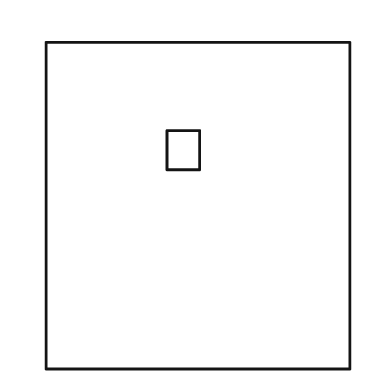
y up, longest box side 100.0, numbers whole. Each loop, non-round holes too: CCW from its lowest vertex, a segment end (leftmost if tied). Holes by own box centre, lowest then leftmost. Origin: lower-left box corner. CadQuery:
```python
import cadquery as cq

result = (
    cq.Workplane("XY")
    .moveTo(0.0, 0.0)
    .lineTo(93.0, 0.0)
    .lineTo(93.0, 100.0)
    .lineTo(0.0, 100.0)
    .close()
    .moveTo(37.0, 61.0)
    .lineTo(47.0, 61.0)
    .lineTo(47.0, 73.0)
    .lineTo(37.0, 73.0)
    .close()
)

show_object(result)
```